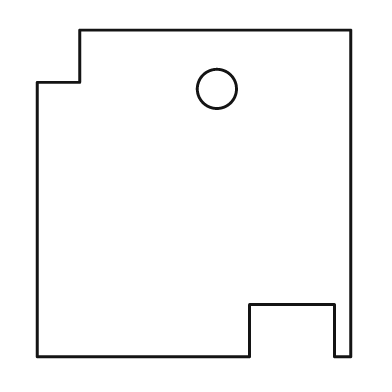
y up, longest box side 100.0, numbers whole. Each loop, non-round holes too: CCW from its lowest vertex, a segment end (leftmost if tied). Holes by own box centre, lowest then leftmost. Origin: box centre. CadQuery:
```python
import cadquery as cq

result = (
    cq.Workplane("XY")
    .moveTo(-48.0, -50.0)
    .lineTo(17.0, -50.0)
    .lineTo(17.0, -34.0)
    .lineTo(43.0, -34.0)
    .lineTo(43.0, -50.0)
    .lineTo(48.0, -50.0)
    .lineTo(48.0, 50.0)
    .lineTo(-35.0, 50.0)
    .lineTo(-35.0, 34.0)
    .lineTo(-48.0, 34.0)
    .close()
    .moveTo(7.0, 32.0)
    .circle(6.0)
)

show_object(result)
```